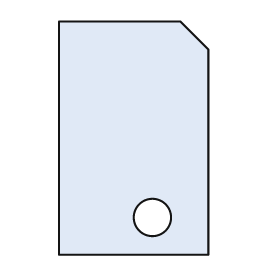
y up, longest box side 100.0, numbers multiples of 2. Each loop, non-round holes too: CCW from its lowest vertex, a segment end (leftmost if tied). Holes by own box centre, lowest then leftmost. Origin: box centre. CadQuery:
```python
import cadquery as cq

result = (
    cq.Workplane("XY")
    .moveTo(-32.0, -50.0)
    .lineTo(32.0, -50.0)
    .lineTo(32.0, 38.0)
    .lineTo(20.0, 50.0)
    .lineTo(-32.0, 50.0)
    .close()
    .moveTo(8.0, -34.0)
    .circle(8.0)
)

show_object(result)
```